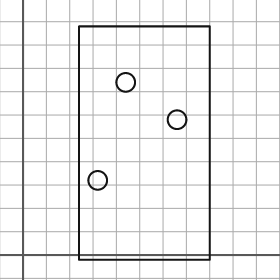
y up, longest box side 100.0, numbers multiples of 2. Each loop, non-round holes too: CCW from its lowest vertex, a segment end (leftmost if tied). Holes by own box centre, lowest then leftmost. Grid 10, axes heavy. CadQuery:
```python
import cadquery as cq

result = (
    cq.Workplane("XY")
    .moveTo(24.0, -2.0)
    .lineTo(80.0, -2.0)
    .lineTo(80.0, 98.0)
    .lineTo(24.0, 98.0)
    .close()
    .moveTo(32.0, 32.0)
    .circle(4.0)
    .moveTo(66.0, 58.0)
    .circle(4.0)
    .moveTo(44.0, 74.0)
    .circle(4.0)
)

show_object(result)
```